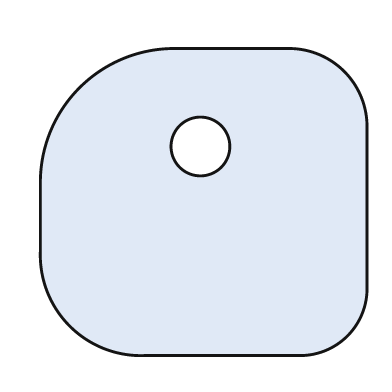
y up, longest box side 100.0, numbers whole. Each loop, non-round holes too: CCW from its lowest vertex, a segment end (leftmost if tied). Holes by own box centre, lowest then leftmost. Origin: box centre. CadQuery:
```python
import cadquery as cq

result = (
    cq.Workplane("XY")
    .moveTo(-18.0, -47.0)
    .lineTo(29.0, -47.0)
    .threePointArc((44.0, -41.0), (50.0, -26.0))
    .lineTo(50.0, 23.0)
    .threePointArc((43.0, 40.0), (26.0, 47.0))
    .lineTo(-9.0, 47.0)
    .threePointArc((-38.0, 35.0), (-50.0, 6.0))
    .lineTo(-50.0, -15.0)
    .threePointArc((-41.0, -38.0), (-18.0, -47.0))
    .close()
    .moveTo(-1.0, 17.0)
    .circle(9.0)
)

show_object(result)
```